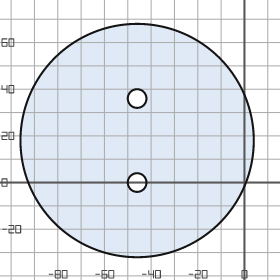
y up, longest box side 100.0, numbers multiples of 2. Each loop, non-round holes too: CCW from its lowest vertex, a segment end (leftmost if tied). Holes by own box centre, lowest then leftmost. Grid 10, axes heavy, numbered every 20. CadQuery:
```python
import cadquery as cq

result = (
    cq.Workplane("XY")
    .moveTo(-46.0, 18.0)
    .circle(50.0)
    .moveTo(-46.0, 0.0)
    .circle(4.0)
    .moveTo(-46.0, 36.0)
    .circle(4.0)
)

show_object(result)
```